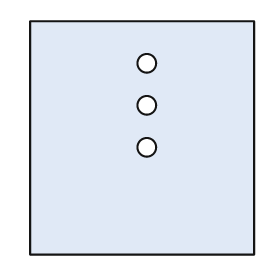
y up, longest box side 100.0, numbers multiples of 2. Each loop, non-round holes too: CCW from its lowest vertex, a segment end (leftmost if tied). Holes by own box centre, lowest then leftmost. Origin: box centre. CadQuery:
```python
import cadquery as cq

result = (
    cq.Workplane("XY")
    .moveTo(-48.0, -50.0)
    .lineTo(48.0, -50.0)
    .lineTo(48.0, 50.0)
    .lineTo(-48.0, 50.0)
    .close()
    .moveTo(2.0, -4.0)
    .circle(4.0)
    .moveTo(2.0, 14.0)
    .circle(4.0)
    .moveTo(2.0, 32.0)
    .circle(4.0)
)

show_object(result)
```